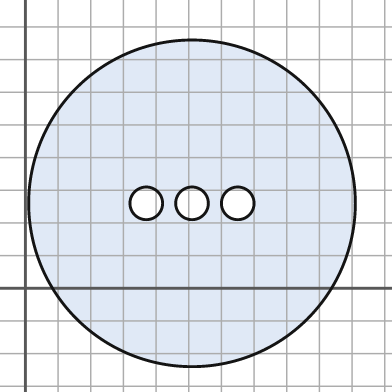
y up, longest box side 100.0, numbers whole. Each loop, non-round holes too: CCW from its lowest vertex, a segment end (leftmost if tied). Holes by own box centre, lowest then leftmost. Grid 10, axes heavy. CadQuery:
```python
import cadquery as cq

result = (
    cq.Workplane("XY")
    .moveTo(51.0, 26.0)
    .circle(50.0)
    .moveTo(37.0, 26.0)
    .circle(5.0)
    .moveTo(51.0, 26.0)
    .circle(5.0)
    .moveTo(65.0, 26.0)
    .circle(5.0)
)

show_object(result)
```